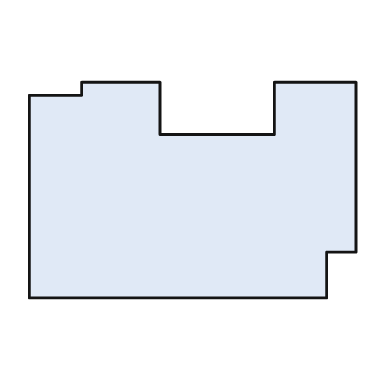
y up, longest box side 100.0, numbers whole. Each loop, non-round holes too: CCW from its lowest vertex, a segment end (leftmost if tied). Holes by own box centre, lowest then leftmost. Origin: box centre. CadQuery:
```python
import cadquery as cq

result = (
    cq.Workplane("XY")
    .moveTo(-50.0, -33.0)
    .lineTo(41.0, -33.0)
    .lineTo(41.0, -19.0)
    .lineTo(50.0, -19.0)
    .lineTo(50.0, 33.0)
    .lineTo(25.0, 33.0)
    .lineTo(25.0, 17.0)
    .lineTo(-10.0, 17.0)
    .lineTo(-10.0, 33.0)
    .lineTo(-34.0, 33.0)
    .lineTo(-34.0, 29.0)
    .lineTo(-50.0, 29.0)
    .close()
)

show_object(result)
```